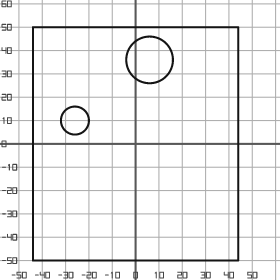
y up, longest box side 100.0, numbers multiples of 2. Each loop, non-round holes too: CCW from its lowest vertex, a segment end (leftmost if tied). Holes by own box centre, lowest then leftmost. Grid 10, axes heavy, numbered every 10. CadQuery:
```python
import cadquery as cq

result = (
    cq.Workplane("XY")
    .moveTo(-44.0, -50.0)
    .lineTo(44.0, -50.0)
    .lineTo(44.0, 50.0)
    .lineTo(-44.0, 50.0)
    .close()
    .moveTo(-26.0, 10.0)
    .circle(6.0)
    .moveTo(6.0, 36.0)
    .circle(10.0)
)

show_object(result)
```